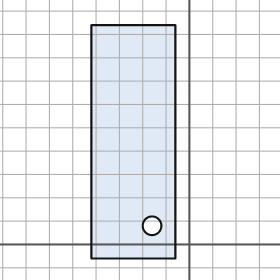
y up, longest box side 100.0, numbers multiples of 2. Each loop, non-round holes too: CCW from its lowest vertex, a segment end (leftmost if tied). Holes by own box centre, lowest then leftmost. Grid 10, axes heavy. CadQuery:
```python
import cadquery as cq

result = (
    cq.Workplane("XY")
    .moveTo(-42.0, -6.0)
    .lineTo(-6.0, -6.0)
    .lineTo(-6.0, 94.0)
    .lineTo(-42.0, 94.0)
    .close()
    .moveTo(-16.0, 8.0)
    .circle(4.0)
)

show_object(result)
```